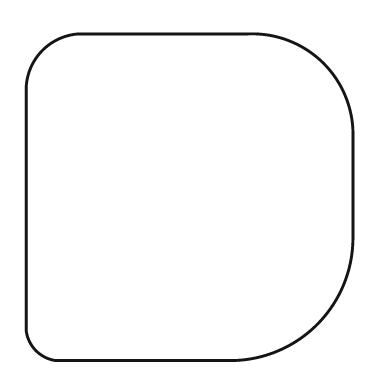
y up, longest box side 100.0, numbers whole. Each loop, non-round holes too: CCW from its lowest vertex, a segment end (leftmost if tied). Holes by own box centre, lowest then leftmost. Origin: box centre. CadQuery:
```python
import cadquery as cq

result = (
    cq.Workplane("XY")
    .moveTo(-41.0, -50.0)
    .lineTo(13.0, -50.0)
    .threePointArc((39.0, -39.0), (50.0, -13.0))
    .lineTo(50.0, 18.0)
    .threePointArc((41.0, 41.0), (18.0, 50.0))
    .lineTo(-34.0, 50.0)
    .threePointArc((-45.0, 45.0), (-50.0, 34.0))
    .lineTo(-50.0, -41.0)
    .threePointArc((-47.0, -47.0), (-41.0, -50.0))
    .close()
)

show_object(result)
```